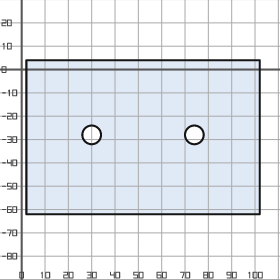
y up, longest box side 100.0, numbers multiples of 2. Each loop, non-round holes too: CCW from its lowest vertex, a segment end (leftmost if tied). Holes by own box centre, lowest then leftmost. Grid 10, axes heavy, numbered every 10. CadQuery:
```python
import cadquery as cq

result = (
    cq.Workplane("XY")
    .moveTo(2.0, -62.0)
    .lineTo(102.0, -62.0)
    .lineTo(102.0, 4.0)
    .lineTo(2.0, 4.0)
    .close()
    .moveTo(30.0, -28.0)
    .circle(4.0)
    .moveTo(74.0, -28.0)
    .circle(4.0)
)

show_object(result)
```